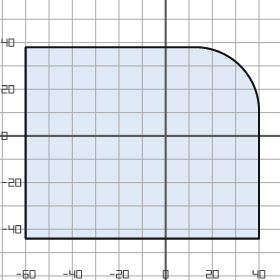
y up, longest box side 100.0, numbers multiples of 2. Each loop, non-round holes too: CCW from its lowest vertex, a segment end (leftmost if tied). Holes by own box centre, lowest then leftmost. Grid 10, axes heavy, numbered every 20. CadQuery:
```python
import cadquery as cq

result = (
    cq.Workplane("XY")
    .moveTo(-60.0, -44.0)
    .lineTo(40.0, -44.0)
    .lineTo(40.0, 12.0)
    .threePointArc((32.0, 30.0), (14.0, 38.0))
    .lineTo(-60.0, 38.0)
    .close()
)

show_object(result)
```